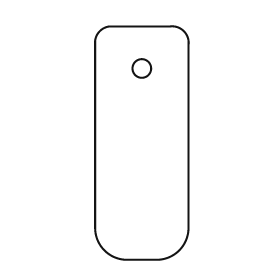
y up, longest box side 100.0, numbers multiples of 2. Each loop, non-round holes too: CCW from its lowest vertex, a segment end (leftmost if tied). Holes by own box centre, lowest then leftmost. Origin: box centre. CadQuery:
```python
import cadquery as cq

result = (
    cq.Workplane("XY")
    .moveTo(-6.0, -50.0)
    .lineTo(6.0, -50.0)
    .threePointArc((16.0, -46.0), (20.0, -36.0))
    .lineTo(20.0, 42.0)
    .threePointArc((18.0, 48.0), (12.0, 50.0))
    .lineTo(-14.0, 50.0)
    .threePointArc((-18.0, 48.0), (-20.0, 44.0))
    .lineTo(-20.0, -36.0)
    .threePointArc((-16.0, -46.0), (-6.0, -50.0))
    .close()
    .moveTo(0.0, 32.0)
    .circle(4.0)
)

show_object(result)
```